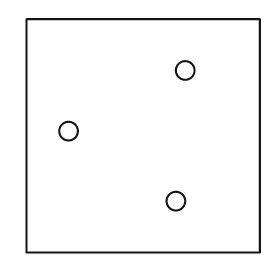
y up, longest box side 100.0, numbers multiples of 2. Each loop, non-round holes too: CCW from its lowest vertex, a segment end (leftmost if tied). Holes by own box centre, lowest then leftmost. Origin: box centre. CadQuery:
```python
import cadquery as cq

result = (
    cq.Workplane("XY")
    .moveTo(-50.0, -50.0)
    .lineTo(50.0, -50.0)
    .lineTo(50.0, 50.0)
    .lineTo(-50.0, 50.0)
    .close()
    .moveTo(14.0, -28.0)
    .circle(4.0)
    .moveTo(-32.0, 2.0)
    .circle(4.0)
    .moveTo(18.0, 28.0)
    .circle(4.0)
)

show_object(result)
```